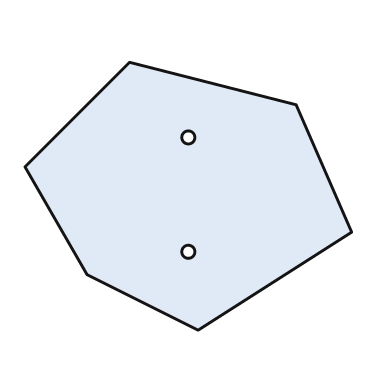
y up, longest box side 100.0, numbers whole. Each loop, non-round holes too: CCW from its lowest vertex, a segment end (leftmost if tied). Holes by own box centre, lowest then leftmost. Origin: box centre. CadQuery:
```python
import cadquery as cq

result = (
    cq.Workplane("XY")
    .moveTo(3.0, -41.0)
    .lineTo(50.0, -11.0)
    .lineTo(33.0, 28.0)
    .lineTo(-18.0, 41.0)
    .lineTo(-50.0, 9.0)
    .lineTo(-31.0, -24.0)
    .close()
    .moveTo(0.0, -17.0)
    .circle(2.0)
    .moveTo(0.0, 18.0)
    .circle(2.0)
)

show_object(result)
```